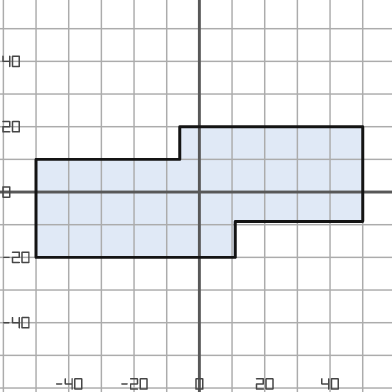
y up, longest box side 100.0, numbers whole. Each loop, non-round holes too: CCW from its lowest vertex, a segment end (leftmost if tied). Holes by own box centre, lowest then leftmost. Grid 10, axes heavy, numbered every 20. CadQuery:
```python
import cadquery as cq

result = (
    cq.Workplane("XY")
    .moveTo(-50.0, -20.0)
    .lineTo(11.0, -20.0)
    .lineTo(11.0, -9.0)
    .lineTo(50.0, -9.0)
    .lineTo(50.0, 20.0)
    .lineTo(-6.0, 20.0)
    .lineTo(-6.0, 10.0)
    .lineTo(-50.0, 10.0)
    .close()
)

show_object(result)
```